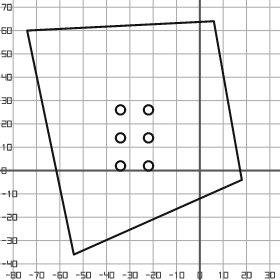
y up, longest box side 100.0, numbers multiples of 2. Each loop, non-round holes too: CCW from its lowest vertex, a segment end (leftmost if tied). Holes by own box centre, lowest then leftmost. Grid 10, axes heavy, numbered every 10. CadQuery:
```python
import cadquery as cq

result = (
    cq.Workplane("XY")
    .moveTo(-54.0, -36.0)
    .lineTo(18.0, -4.0)
    .lineTo(6.0, 64.0)
    .lineTo(-74.0, 60.0)
    .close()
    .moveTo(-34.0, 2.0)
    .circle(2.0)
    .moveTo(-22.0, 2.0)
    .circle(2.0)
    .moveTo(-34.0, 14.0)
    .circle(2.0)
    .moveTo(-22.0, 14.0)
    .circle(2.0)
    .moveTo(-34.0, 26.0)
    .circle(2.0)
    .moveTo(-22.0, 26.0)
    .circle(2.0)
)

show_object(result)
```